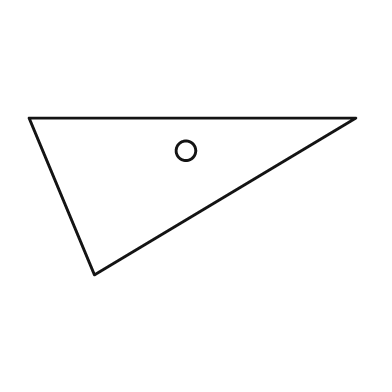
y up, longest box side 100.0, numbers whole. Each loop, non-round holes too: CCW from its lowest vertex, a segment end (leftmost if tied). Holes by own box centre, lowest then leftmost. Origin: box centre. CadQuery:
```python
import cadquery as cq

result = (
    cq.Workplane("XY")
    .moveTo(-30.0, -24.0)
    .lineTo(50.0, 24.0)
    .lineTo(-50.0, 24.0)
    .close()
    .moveTo(-2.0, 14.0)
    .circle(3.0)
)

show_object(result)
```